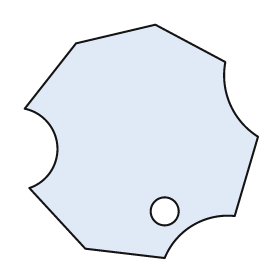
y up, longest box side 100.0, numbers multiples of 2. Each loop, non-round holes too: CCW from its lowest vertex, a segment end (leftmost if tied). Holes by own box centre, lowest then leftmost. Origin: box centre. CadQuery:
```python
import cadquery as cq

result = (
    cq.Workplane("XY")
    .moveTo(10.0, -50.0)
    .threePointArc((22.0, -36.0), (40.0, -32.0))
    .lineTo(50.0, 2.0)
    .threePointArc((38.0, 16.0), (36.0, 34.0))
    .lineTo(6.0, 50.0)
    .lineTo(-28.0, 42.0)
    .lineTo(-50.0, 14.0)
    .threePointArc((-36.0, -2.0), (-48.0, -20.0))
    .lineTo(-24.0, -46.0)
    .close()
    .moveTo(10.0, -30.0)
    .circle(6.0)
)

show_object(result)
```